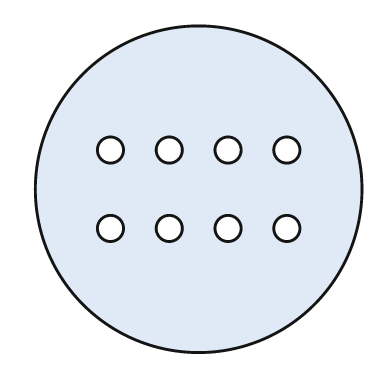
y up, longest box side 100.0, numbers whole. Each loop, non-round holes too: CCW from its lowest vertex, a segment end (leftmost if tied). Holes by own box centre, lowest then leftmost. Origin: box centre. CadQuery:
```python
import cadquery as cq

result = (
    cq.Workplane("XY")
    .moveTo(0.0, 0.0)
    .circle(50.0)
    .moveTo(-27.0, -12.0)
    .circle(4.0)
    .moveTo(-9.0, -12.0)
    .circle(4.0)
    .moveTo(9.0, -12.0)
    .circle(4.0)
    .moveTo(27.0, -12.0)
    .circle(4.0)
    .moveTo(-27.0, 12.0)
    .circle(4.0)
    .moveTo(-9.0, 12.0)
    .circle(4.0)
    .moveTo(9.0, 12.0)
    .circle(4.0)
    .moveTo(27.0, 12.0)
    .circle(4.0)
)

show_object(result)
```